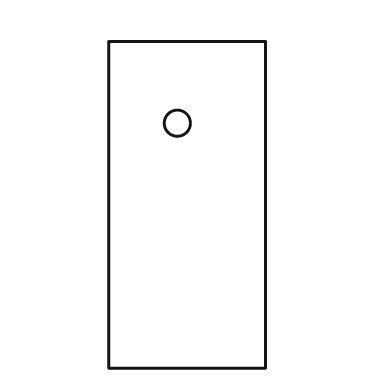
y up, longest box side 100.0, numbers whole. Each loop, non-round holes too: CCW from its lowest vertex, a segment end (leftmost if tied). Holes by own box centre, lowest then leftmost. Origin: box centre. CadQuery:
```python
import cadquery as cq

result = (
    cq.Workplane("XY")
    .moveTo(-24.0, -50.0)
    .lineTo(24.0, -50.0)
    .lineTo(24.0, 50.0)
    .lineTo(-24.0, 50.0)
    .close()
    .moveTo(-3.0, 25.0)
    .circle(4.0)
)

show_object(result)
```